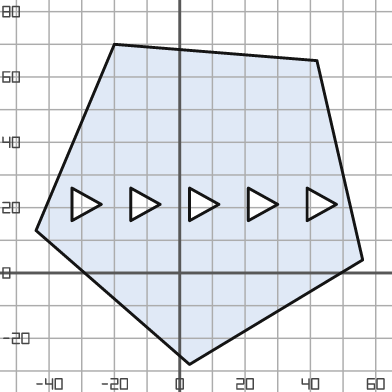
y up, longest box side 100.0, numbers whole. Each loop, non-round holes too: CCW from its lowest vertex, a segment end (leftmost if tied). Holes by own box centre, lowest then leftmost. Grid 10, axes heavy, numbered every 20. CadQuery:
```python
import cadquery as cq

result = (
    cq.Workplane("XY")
    .moveTo(3.0, -28.0)
    .lineTo(56.0, 4.0)
    .lineTo(42.0, 65.0)
    .lineTo(-20.0, 70.0)
    .lineTo(-44.0, 13.0)
    .close()
    .moveTo(-33.0, 16.0)
    .lineTo(-24.0, 21.0)
    .lineTo(-33.0, 26.0)
    .close()
    .moveTo(-15.0, 16.0)
    .lineTo(-6.0, 21.0)
    .lineTo(-15.0, 26.0)
    .close()
    .moveTo(3.0, 16.0)
    .lineTo(12.0, 21.0)
    .lineTo(3.0, 26.0)
    .close()
    .moveTo(21.0, 16.0)
    .lineTo(30.0, 21.0)
    .lineTo(21.0, 26.0)
    .close()
    .moveTo(39.0, 16.0)
    .lineTo(48.0, 21.0)
    .lineTo(39.0, 26.0)
    .close()
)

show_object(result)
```